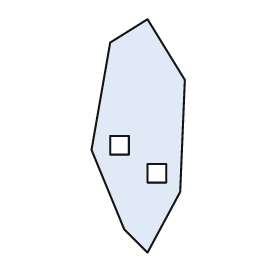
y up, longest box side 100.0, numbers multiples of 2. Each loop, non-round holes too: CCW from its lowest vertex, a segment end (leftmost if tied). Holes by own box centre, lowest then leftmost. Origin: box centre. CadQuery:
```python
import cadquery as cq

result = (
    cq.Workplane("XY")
    .moveTo(4.0, -50.0)
    .lineTo(18.0, -24.0)
    .lineTo(20.0, 24.0)
    .lineTo(4.0, 50.0)
    .lineTo(-12.0, 40.0)
    .lineTo(-20.0, -6.0)
    .lineTo(-6.0, -40.0)
    .close()
    .moveTo(4.0, -20.0)
    .lineTo(12.0, -20.0)
    .lineTo(12.0, -12.0)
    .lineTo(4.0, -12.0)
    .close()
    .moveTo(-12.0, -8.0)
    .lineTo(-4.0, -8.0)
    .lineTo(-4.0, 0.0)
    .lineTo(-12.0, 0.0)
    .close()
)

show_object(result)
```